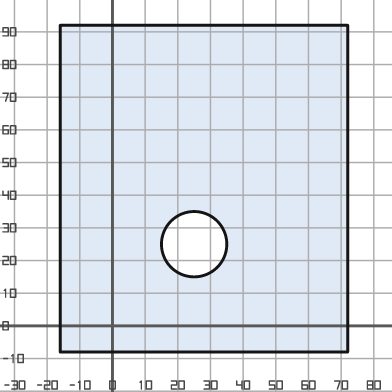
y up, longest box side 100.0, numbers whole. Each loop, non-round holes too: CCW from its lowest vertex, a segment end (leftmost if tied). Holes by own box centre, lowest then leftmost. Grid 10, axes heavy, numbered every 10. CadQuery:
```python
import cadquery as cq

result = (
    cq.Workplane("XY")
    .moveTo(-16.0, -8.0)
    .lineTo(72.0, -8.0)
    .lineTo(72.0, 92.0)
    .lineTo(-16.0, 92.0)
    .close()
    .moveTo(25.0, 25.0)
    .circle(10.0)
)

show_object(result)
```